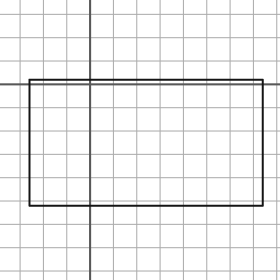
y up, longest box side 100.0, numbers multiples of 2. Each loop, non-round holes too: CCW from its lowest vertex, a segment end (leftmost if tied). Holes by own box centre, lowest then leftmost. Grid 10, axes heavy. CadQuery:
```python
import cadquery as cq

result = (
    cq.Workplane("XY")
    .moveTo(-26.0, -52.0)
    .lineTo(74.0, -52.0)
    .lineTo(74.0, 2.0)
    .lineTo(-26.0, 2.0)
    .close()
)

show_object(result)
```